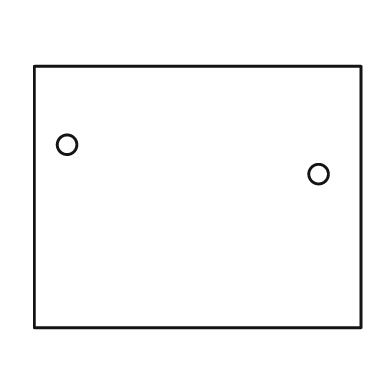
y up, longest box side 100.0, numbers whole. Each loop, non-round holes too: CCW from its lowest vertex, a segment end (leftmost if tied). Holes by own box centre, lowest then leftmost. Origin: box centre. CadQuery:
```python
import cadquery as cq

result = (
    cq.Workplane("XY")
    .moveTo(-50.0, -40.0)
    .lineTo(50.0, -40.0)
    .lineTo(50.0, 40.0)
    .lineTo(-50.0, 40.0)
    .close()
    .moveTo(37.0, 7.0)
    .circle(3.0)
    .moveTo(-40.0, 16.0)
    .circle(3.0)
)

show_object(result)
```